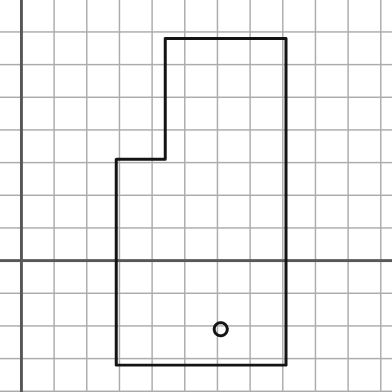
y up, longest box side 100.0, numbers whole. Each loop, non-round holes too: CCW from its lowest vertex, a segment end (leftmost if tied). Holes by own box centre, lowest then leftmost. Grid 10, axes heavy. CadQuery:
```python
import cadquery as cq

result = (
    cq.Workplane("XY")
    .moveTo(29.0, -32.0)
    .lineTo(81.0, -32.0)
    .lineTo(81.0, 68.0)
    .lineTo(44.0, 68.0)
    .lineTo(44.0, 31.0)
    .lineTo(29.0, 31.0)
    .close()
    .moveTo(61.0, -21.0)
    .circle(2.0)
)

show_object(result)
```